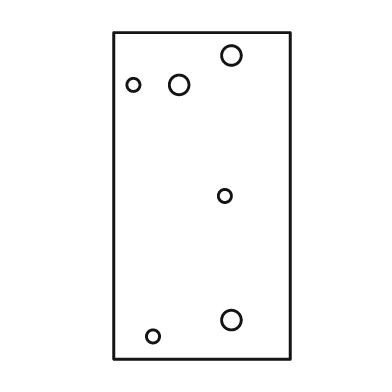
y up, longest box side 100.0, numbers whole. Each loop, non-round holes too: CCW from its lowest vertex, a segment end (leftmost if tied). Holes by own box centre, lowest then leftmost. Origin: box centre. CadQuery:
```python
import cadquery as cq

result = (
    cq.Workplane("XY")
    .moveTo(-27.0, -50.0)
    .lineTo(27.0, -50.0)
    .lineTo(27.0, 50.0)
    .lineTo(-27.0, 50.0)
    .close()
    .moveTo(-15.0, -43.0)
    .circle(2.0)
    .moveTo(9.0, -38.0)
    .circle(3.0)
    .moveTo(7.0, 0.0)
    .circle(2.0)
    .moveTo(-21.0, 34.0)
    .circle(2.0)
    .moveTo(-7.0, 34.0)
    .circle(3.0)
    .moveTo(9.0, 43.0)
    .circle(3.0)
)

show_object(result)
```